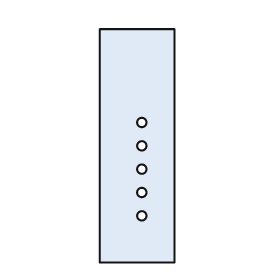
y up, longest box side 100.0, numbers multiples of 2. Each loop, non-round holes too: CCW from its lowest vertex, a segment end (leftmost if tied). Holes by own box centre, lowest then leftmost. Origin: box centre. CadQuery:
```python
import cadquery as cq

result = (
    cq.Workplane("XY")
    .moveTo(-16.0, -50.0)
    .lineTo(16.0, -50.0)
    .lineTo(16.0, 50.0)
    .lineTo(-16.0, 50.0)
    .close()
    .moveTo(2.0, -30.0)
    .circle(2.0)
    .moveTo(2.0, -20.0)
    .circle(2.0)
    .moveTo(2.0, -10.0)
    .circle(2.0)
    .moveTo(2.0, 0.0)
    .circle(2.0)
    .moveTo(2.0, 10.0)
    .circle(2.0)
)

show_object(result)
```